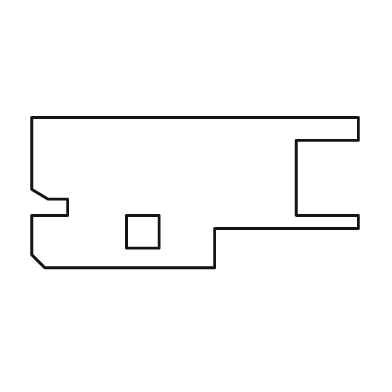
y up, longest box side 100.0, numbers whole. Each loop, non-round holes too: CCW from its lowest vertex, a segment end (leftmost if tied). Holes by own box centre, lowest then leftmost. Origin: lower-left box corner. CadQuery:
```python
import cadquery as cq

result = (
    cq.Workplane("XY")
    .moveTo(4.0, 0.0)
    .lineTo(56.0, 0.0)
    .lineTo(56.0, 12.0)
    .lineTo(100.0, 12.0)
    .lineTo(100.0, 16.0)
    .lineTo(81.0, 16.0)
    .lineTo(81.0, 39.0)
    .lineTo(100.0, 39.0)
    .lineTo(100.0, 46.0)
    .lineTo(0.0, 46.0)
    .lineTo(0.0, 24.0)
    .lineTo(5.0, 21.0)
    .lineTo(11.0, 21.0)
    .lineTo(11.0, 16.0)
    .lineTo(0.0, 16.0)
    .lineTo(0.0, 4.0)
    .close()
    .moveTo(29.0, 6.0)
    .lineTo(39.0, 6.0)
    .lineTo(39.0, 16.0)
    .lineTo(29.0, 16.0)
    .close()
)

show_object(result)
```